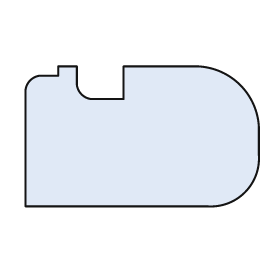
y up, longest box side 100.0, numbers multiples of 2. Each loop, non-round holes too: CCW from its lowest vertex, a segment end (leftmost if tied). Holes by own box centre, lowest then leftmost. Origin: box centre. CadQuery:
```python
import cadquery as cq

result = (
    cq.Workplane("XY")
    .moveTo(-50.0, -30.0)
    .lineTo(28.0, -30.0)
    .threePointArc((44.0, -24.0), (50.0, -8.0))
    .lineTo(50.0, 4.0)
    .threePointArc((42.0, 22.0), (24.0, 30.0))
    .lineTo(-8.0, 30.0)
    .lineTo(-8.0, 16.0)
    .lineTo(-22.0, 16.0)
    .threePointArc((-26.0, 18.0), (-28.0, 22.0))
    .lineTo(-28.0, 30.0)
    .lineTo(-36.0, 30.0)
    .lineTo(-36.0, 26.0)
    .lineTo(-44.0, 26.0)
    .threePointArc((-48.0, 24.0), (-50.0, 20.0))
    .close()
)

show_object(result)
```